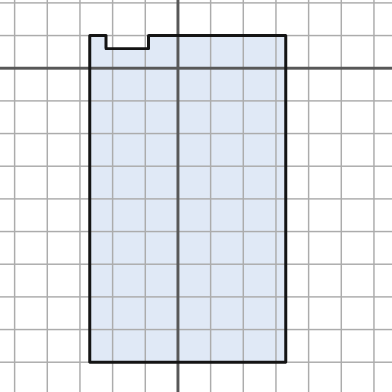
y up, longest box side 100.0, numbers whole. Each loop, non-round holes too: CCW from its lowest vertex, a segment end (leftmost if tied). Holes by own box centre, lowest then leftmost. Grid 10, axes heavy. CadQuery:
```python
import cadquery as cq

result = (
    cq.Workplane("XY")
    .moveTo(-27.0, -90.0)
    .lineTo(33.0, -90.0)
    .lineTo(33.0, 10.0)
    .lineTo(-9.0, 10.0)
    .lineTo(-9.0, 6.0)
    .lineTo(-22.0, 6.0)
    .lineTo(-22.0, 10.0)
    .lineTo(-27.0, 10.0)
    .close()
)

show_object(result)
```